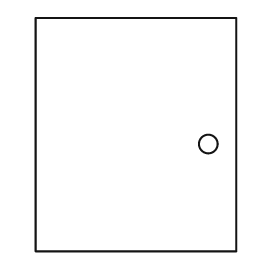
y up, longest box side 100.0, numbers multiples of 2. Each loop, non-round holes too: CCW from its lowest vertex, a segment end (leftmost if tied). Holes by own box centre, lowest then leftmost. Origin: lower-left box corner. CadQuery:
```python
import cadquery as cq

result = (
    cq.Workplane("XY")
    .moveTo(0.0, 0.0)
    .lineTo(86.0, 0.0)
    .lineTo(86.0, 100.0)
    .lineTo(0.0, 100.0)
    .close()
    .moveTo(74.0, 46.0)
    .circle(4.0)
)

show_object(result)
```